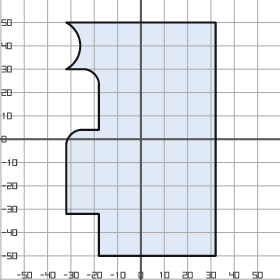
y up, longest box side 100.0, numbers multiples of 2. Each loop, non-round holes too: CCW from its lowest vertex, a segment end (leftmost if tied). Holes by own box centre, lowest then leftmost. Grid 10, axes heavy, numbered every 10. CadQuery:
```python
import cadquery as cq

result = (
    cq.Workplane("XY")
    .moveTo(-18.0, -50.0)
    .lineTo(32.0, -50.0)
    .lineTo(32.0, 50.0)
    .lineTo(-32.0, 50.0)
    .threePointArc((-26.0, 40.0), (-32.0, 30.0))
    .lineTo(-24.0, 30.0)
    .threePointArc((-20.0, 28.0), (-18.0, 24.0))
    .lineTo(-18.0, 4.0)
    .lineTo(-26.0, 4.0)
    .threePointArc((-30.0, 2.0), (-32.0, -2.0))
    .lineTo(-32.0, -32.0)
    .lineTo(-18.0, -32.0)
    .close()
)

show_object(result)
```